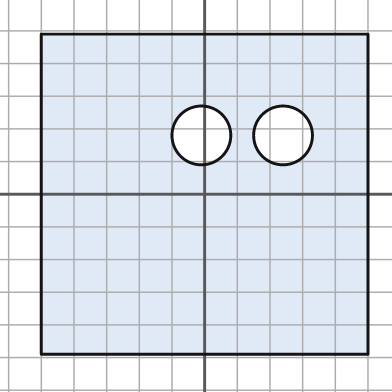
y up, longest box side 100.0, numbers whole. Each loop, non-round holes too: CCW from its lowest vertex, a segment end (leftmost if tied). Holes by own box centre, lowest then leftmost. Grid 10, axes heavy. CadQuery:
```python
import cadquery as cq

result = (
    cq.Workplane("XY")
    .moveTo(-50.0, -49.0)
    .lineTo(50.0, -49.0)
    .lineTo(50.0, 49.0)
    .lineTo(-50.0, 49.0)
    .close()
    .moveTo(-1.0, 18.0)
    .circle(9.0)
    .moveTo(24.0, 18.0)
    .circle(9.0)
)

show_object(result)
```